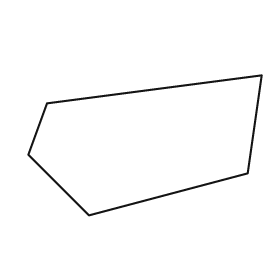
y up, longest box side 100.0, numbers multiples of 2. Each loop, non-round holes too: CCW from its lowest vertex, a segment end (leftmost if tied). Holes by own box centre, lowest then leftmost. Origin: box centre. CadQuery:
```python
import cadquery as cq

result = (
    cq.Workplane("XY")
    .moveTo(-24.0, -30.0)
    .lineTo(44.0, -12.0)
    .lineTo(50.0, 30.0)
    .lineTo(-42.0, 18.0)
    .lineTo(-50.0, -4.0)
    .close()
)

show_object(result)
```